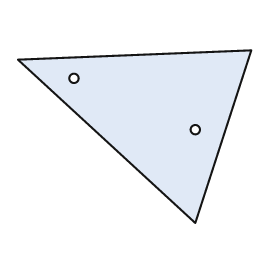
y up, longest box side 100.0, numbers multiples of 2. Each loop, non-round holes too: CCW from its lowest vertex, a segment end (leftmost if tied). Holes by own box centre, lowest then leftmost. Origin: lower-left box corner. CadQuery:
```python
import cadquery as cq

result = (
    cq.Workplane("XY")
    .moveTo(76.0, 0.0)
    .lineTo(100.0, 74.0)
    .lineTo(0.0, 70.0)
    .close()
    .moveTo(76.0, 40.0)
    .circle(2.0)
    .moveTo(24.0, 62.0)
    .circle(2.0)
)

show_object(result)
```